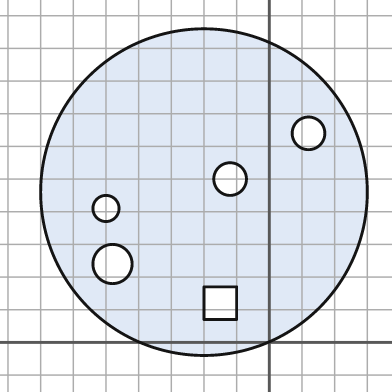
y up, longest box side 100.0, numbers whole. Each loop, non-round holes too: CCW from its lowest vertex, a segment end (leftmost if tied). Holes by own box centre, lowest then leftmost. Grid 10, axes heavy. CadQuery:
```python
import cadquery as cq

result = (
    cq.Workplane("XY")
    .moveTo(-20.0, 46.0)
    .circle(50.0)
    .moveTo(-20.0, 7.0)
    .lineTo(-10.0, 7.0)
    .lineTo(-10.0, 17.0)
    .lineTo(-20.0, 17.0)
    .close()
    .moveTo(-48.0, 24.0)
    .circle(6.0)
    .moveTo(-50.0, 41.0)
    .circle(4.0)
    .moveTo(-12.0, 50.0)
    .circle(5.0)
    .moveTo(12.0, 64.0)
    .circle(5.0)
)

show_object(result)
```